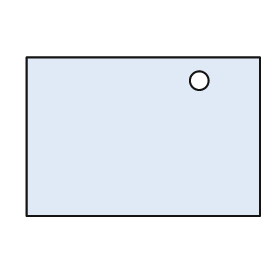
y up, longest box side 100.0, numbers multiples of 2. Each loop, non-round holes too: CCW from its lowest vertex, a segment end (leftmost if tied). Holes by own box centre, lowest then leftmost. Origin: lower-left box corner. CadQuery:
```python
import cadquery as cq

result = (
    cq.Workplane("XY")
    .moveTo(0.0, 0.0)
    .lineTo(100.0, 0.0)
    .lineTo(100.0, 68.0)
    .lineTo(0.0, 68.0)
    .close()
    .moveTo(74.0, 58.0)
    .circle(4.0)
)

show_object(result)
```